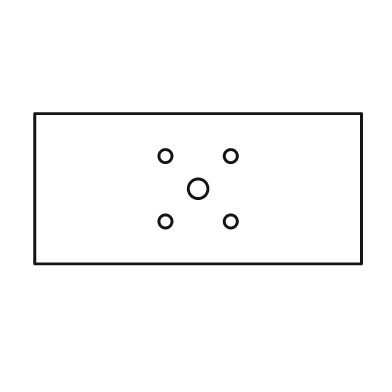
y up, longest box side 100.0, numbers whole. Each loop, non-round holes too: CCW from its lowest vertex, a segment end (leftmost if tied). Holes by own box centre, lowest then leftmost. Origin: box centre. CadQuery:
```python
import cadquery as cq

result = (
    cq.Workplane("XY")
    .moveTo(-50.0, -23.0)
    .lineTo(50.0, -23.0)
    .lineTo(50.0, 23.0)
    .lineTo(-50.0, 23.0)
    .close()
    .moveTo(-10.0, -10.0)
    .circle(2.0)
    .moveTo(10.0, -10.0)
    .circle(2.0)
    .moveTo(0.0, 0.0)
    .circle(3.0)
    .moveTo(-10.0, 10.0)
    .circle(2.0)
    .moveTo(10.0, 10.0)
    .circle(2.0)
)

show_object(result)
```